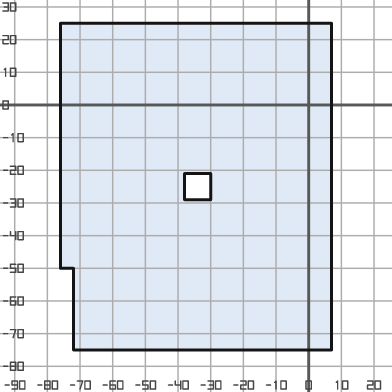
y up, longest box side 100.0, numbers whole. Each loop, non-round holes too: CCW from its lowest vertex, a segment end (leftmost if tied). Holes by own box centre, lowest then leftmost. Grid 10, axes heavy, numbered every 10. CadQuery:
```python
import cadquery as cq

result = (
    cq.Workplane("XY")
    .moveTo(-72.0, -75.0)
    .lineTo(7.0, -75.0)
    .lineTo(7.0, 25.0)
    .lineTo(-76.0, 25.0)
    .lineTo(-76.0, -50.0)
    .lineTo(-72.0, -50.0)
    .close()
    .moveTo(-38.0, -29.0)
    .lineTo(-30.0, -29.0)
    .lineTo(-30.0, -21.0)
    .lineTo(-38.0, -21.0)
    .close()
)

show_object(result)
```